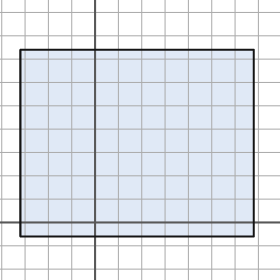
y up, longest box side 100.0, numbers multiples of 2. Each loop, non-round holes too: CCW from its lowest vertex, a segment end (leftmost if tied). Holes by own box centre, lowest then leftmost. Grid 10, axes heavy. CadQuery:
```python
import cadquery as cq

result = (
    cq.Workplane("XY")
    .moveTo(-32.0, -6.0)
    .lineTo(68.0, -6.0)
    .lineTo(68.0, 74.0)
    .lineTo(-32.0, 74.0)
    .close()
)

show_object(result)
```